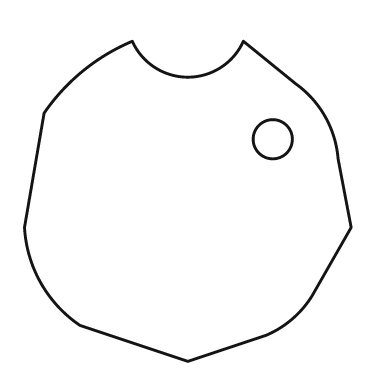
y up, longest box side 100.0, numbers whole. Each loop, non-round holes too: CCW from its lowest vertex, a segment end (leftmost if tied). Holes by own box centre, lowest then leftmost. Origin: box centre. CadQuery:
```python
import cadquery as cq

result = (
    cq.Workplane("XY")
    .moveTo(0.0, -49.0)
    .lineTo(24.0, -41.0)
    .threePointArc((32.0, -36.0), (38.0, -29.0))
    .lineTo(50.0, -8.0)
    .lineTo(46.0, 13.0)
    .threePointArc((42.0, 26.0), (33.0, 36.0))
    .lineTo(17.0, 49.0)
    .threePointArc((0.0, 38.0), (-17.0, 49.0))
    .threePointArc((-32.0, 40.0), (-44.0, 27.0))
    .lineTo(-50.0, -8.0)
    .threePointArc((-45.0, -25.0), (-33.0, -38.0))
    .close()
    .moveTo(26.0, 19.0)
    .circle(6.0)
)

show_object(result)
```